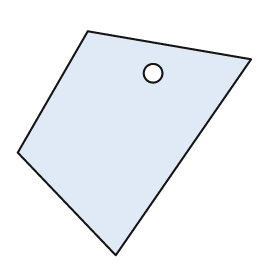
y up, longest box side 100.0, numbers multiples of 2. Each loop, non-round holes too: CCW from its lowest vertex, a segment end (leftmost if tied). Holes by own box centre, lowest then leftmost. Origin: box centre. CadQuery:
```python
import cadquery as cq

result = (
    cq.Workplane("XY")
    .moveTo(-8.0, -48.0)
    .lineTo(50.0, 36.0)
    .lineTo(-20.0, 48.0)
    .lineTo(-50.0, -4.0)
    .close()
    .moveTo(8.0, 30.0)
    .circle(4.0)
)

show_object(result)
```